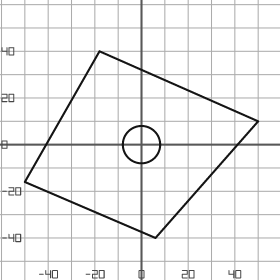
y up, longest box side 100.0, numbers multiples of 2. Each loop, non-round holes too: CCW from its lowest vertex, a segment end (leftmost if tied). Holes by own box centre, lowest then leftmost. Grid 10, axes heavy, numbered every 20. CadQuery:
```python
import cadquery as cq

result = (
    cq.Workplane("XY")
    .moveTo(6.0, -40.0)
    .lineTo(50.0, 10.0)
    .lineTo(-18.0, 40.0)
    .lineTo(-50.0, -16.0)
    .close()
    .moveTo(0.0, 0.0)
    .circle(8.0)
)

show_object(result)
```